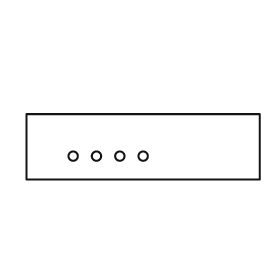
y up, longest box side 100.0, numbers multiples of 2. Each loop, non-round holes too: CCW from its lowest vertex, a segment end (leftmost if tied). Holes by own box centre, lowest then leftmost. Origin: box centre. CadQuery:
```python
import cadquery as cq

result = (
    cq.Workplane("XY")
    .moveTo(-50.0, -14.0)
    .lineTo(50.0, -14.0)
    .lineTo(50.0, 14.0)
    .lineTo(-50.0, 14.0)
    .close()
    .moveTo(-30.0, -4.0)
    .circle(2.0)
    .moveTo(-20.0, -4.0)
    .circle(2.0)
    .moveTo(-10.0, -4.0)
    .circle(2.0)
    .moveTo(0.0, -4.0)
    .circle(2.0)
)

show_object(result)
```